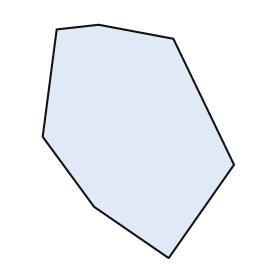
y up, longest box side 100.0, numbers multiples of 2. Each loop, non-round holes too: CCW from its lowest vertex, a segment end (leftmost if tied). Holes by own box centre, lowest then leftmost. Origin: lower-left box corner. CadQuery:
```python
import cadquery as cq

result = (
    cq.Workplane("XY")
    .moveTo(54.0, 0.0)
    .lineTo(82.0, 40.0)
    .lineTo(56.0, 94.0)
    .lineTo(24.0, 100.0)
    .lineTo(6.0, 98.0)
    .lineTo(0.0, 52.0)
    .lineTo(22.0, 22.0)
    .close()
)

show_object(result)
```